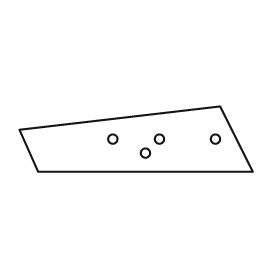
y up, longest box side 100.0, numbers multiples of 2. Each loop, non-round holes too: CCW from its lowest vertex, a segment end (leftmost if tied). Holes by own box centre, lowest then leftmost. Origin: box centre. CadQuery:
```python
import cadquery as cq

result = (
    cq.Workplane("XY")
    .moveTo(-42.0, -14.0)
    .lineTo(50.0, -14.0)
    .lineTo(36.0, 14.0)
    .lineTo(-50.0, 4.0)
    .close()
    .moveTo(4.0, -6.0)
    .circle(2.0)
    .moveTo(-10.0, 0.0)
    .circle(2.0)
    .moveTo(10.0, 0.0)
    .circle(2.0)
    .moveTo(34.0, 0.0)
    .circle(2.0)
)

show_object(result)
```